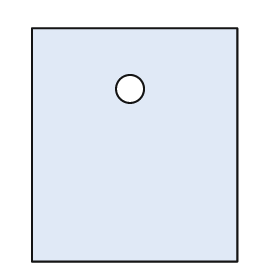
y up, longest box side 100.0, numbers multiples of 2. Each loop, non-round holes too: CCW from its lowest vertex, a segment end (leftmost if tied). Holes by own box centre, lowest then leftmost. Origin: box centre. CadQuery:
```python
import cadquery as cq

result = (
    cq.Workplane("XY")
    .moveTo(-44.0, -50.0)
    .lineTo(44.0, -50.0)
    .lineTo(44.0, 50.0)
    .lineTo(-44.0, 50.0)
    .close()
    .moveTo(-2.0, 24.0)
    .circle(6.0)
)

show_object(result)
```